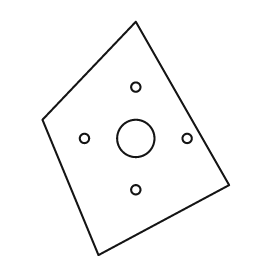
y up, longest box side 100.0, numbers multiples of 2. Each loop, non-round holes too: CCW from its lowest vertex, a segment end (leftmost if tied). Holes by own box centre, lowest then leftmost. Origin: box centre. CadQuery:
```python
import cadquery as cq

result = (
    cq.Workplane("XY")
    .moveTo(-16.0, -50.0)
    .lineTo(40.0, -20.0)
    .lineTo(0.0, 50.0)
    .lineTo(-40.0, 8.0)
    .close()
    .moveTo(0.0, -22.0)
    .circle(2.0)
    .moveTo(-22.0, 0.0)
    .circle(2.0)
    .moveTo(0.0, 0.0)
    .circle(8.0)
    .moveTo(22.0, 0.0)
    .circle(2.0)
    .moveTo(0.0, 22.0)
    .circle(2.0)
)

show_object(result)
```